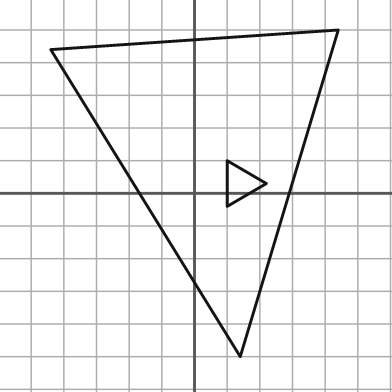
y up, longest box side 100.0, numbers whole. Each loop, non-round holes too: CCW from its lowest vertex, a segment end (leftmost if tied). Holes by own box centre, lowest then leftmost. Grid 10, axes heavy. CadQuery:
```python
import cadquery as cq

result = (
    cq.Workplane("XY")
    .moveTo(14.0, -50.0)
    .lineTo(44.0, 50.0)
    .lineTo(-44.0, 44.0)
    .close()
    .moveTo(10.0, -4.0)
    .lineTo(22.0, 3.0)
    .lineTo(10.0, 10.0)
    .close()
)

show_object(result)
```